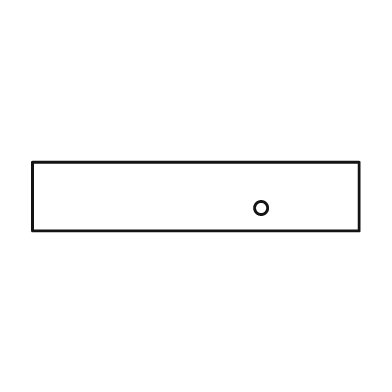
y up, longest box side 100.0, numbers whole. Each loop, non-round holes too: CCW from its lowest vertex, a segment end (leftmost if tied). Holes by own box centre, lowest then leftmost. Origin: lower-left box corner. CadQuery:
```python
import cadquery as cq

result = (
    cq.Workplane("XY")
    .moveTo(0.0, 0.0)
    .lineTo(100.0, 0.0)
    .lineTo(100.0, 21.0)
    .lineTo(0.0, 21.0)
    .close()
    .moveTo(70.0, 7.0)
    .circle(2.0)
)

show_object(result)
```